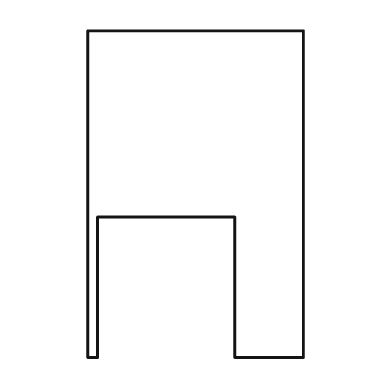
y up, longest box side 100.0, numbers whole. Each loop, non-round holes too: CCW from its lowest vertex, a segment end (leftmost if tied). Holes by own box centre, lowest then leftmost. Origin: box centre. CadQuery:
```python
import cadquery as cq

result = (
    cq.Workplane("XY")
    .moveTo(-33.0, -50.0)
    .lineTo(-30.0, -50.0)
    .lineTo(-30.0, -7.0)
    .lineTo(12.0, -7.0)
    .lineTo(12.0, -50.0)
    .lineTo(33.0, -50.0)
    .lineTo(33.0, 50.0)
    .lineTo(-33.0, 50.0)
    .close()
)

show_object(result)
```